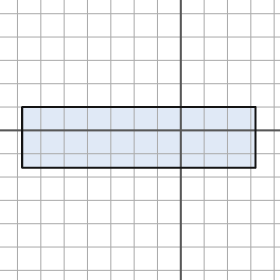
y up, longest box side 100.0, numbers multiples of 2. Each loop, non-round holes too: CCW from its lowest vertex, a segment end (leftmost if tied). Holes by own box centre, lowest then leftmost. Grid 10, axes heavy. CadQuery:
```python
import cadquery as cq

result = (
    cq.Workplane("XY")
    .moveTo(-68.0, -16.0)
    .lineTo(32.0, -16.0)
    .lineTo(32.0, 10.0)
    .lineTo(-68.0, 10.0)
    .close()
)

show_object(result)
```